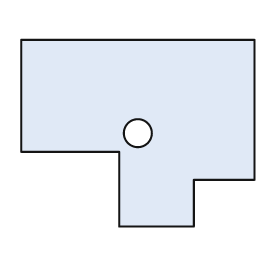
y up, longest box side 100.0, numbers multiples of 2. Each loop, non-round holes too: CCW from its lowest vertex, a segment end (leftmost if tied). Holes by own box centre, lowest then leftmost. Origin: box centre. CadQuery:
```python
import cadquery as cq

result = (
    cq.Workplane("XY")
    .moveTo(-8.0, -40.0)
    .lineTo(24.0, -40.0)
    .lineTo(24.0, -20.0)
    .lineTo(50.0, -20.0)
    .lineTo(50.0, 40.0)
    .lineTo(-50.0, 40.0)
    .lineTo(-50.0, -8.0)
    .lineTo(-8.0, -8.0)
    .close()
    .moveTo(0.0, 0.0)
    .circle(6.0)
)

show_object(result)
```